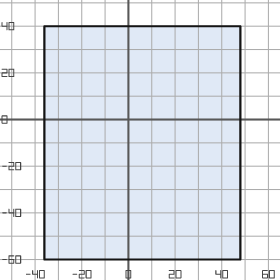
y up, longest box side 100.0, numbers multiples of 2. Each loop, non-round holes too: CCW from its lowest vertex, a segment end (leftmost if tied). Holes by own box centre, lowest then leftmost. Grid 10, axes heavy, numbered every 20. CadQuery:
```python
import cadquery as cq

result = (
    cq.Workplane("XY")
    .moveTo(-36.0, -60.0)
    .lineTo(48.0, -60.0)
    .lineTo(48.0, 40.0)
    .lineTo(-36.0, 40.0)
    .close()
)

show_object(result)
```